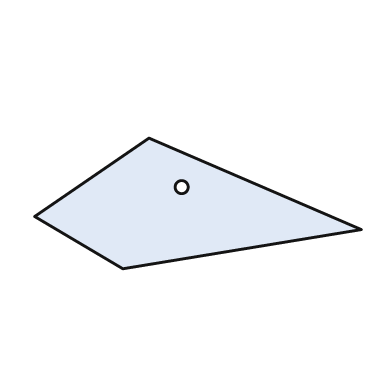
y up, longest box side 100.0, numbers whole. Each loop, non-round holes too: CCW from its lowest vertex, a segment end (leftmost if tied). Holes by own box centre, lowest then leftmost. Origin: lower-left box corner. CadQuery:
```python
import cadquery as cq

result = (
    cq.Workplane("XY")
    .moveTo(27.0, 0.0)
    .lineTo(100.0, 12.0)
    .lineTo(35.0, 40.0)
    .lineTo(0.0, 16.0)
    .close()
    .moveTo(45.0, 25.0)
    .circle(2.0)
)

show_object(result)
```